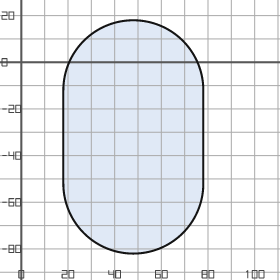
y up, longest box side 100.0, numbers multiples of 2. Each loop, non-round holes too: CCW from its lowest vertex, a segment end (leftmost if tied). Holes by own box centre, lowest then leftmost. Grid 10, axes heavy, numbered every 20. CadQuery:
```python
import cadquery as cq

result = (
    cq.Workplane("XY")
    .moveTo(18.0, -52.0)
    .threePointArc((48.0, -82.0), (78.0, -52.0))
    .lineTo(78.0, -12.0)
    .threePointArc((48.0, 18.0), (18.0, -12.0))
    .close()
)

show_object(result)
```